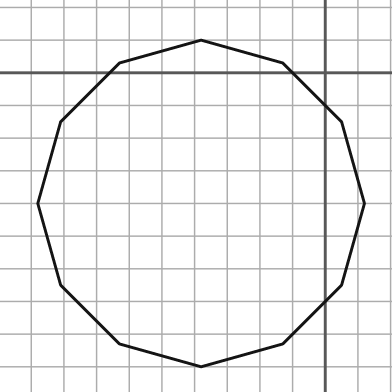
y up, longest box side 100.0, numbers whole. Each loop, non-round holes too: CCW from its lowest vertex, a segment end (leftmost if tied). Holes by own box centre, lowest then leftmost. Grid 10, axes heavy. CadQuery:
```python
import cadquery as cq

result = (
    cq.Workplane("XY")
    .moveTo(-38.0, -90.0)
    .lineTo(-13.0, -83.0)
    .lineTo(5.0, -65.0)
    .lineTo(12.0, -40.0)
    .lineTo(5.0, -15.0)
    .lineTo(-13.0, 3.0)
    .lineTo(-38.0, 10.0)
    .lineTo(-63.0, 3.0)
    .lineTo(-81.0, -15.0)
    .lineTo(-88.0, -40.0)
    .lineTo(-81.0, -65.0)
    .lineTo(-63.0, -83.0)
    .close()
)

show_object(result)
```